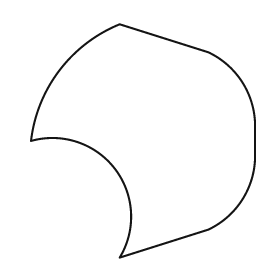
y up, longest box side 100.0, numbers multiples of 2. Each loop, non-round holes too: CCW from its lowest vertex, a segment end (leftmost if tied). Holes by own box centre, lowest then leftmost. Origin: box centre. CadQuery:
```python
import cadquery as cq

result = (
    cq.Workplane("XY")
    .moveTo(-10.0, -50.0)
    .lineTo(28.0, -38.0)
    .threePointArc((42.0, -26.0), (48.0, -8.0))
    .lineTo(48.0, 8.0)
    .threePointArc((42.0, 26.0), (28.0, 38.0))
    .lineTo(-10.0, 50.0)
    .threePointArc((-36.0, 30.0), (-48.0, 0.0))
    .threePointArc((-12.0, -12.0), (-10.0, -50.0))
    .close()
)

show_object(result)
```